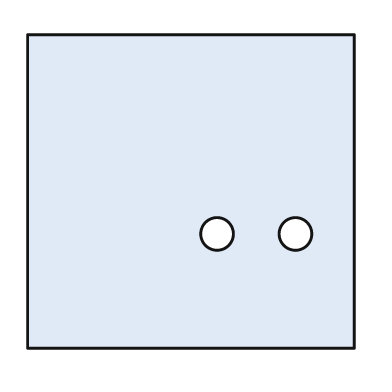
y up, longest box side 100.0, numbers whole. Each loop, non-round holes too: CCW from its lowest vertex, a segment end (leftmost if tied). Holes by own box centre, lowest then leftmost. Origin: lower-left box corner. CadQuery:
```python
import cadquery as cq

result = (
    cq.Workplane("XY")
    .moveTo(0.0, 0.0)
    .lineTo(100.0, 0.0)
    .lineTo(100.0, 96.0)
    .lineTo(0.0, 96.0)
    .close()
    .moveTo(58.0, 35.0)
    .circle(5.0)
    .moveTo(82.0, 35.0)
    .circle(5.0)
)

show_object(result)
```